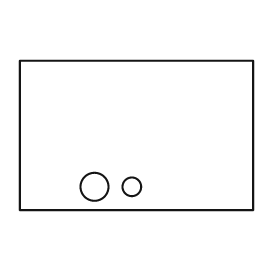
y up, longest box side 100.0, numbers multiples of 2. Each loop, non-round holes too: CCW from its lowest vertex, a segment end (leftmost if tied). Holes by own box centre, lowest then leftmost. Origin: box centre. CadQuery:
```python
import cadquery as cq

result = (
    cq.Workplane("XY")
    .moveTo(-50.0, -32.0)
    .lineTo(50.0, -32.0)
    .lineTo(50.0, 32.0)
    .lineTo(-50.0, 32.0)
    .close()
    .moveTo(-18.0, -22.0)
    .circle(6.0)
    .moveTo(-2.0, -22.0)
    .circle(4.0)
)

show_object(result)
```